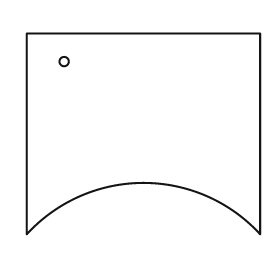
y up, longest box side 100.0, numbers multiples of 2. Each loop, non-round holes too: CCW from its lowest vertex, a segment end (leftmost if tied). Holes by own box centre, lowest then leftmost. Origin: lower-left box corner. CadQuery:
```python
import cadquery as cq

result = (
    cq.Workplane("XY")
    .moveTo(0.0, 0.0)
    .threePointArc((50.0, 22.0), (100.0, 0.0))
    .lineTo(100.0, 86.0)
    .lineTo(0.0, 86.0)
    .close()
    .moveTo(16.0, 74.0)
    .circle(2.0)
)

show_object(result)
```